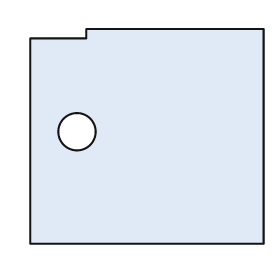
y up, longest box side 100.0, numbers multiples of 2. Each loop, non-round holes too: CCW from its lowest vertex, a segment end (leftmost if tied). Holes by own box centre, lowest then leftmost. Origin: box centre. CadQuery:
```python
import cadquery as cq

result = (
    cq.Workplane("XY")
    .moveTo(-50.0, -46.0)
    .lineTo(50.0, -46.0)
    .lineTo(50.0, 46.0)
    .lineTo(-26.0, 46.0)
    .lineTo(-26.0, 42.0)
    .lineTo(-50.0, 42.0)
    .close()
    .moveTo(-30.0, 2.0)
    .circle(8.0)
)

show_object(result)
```